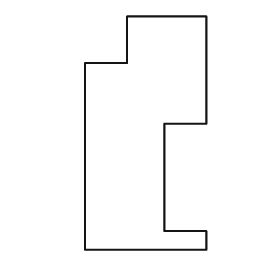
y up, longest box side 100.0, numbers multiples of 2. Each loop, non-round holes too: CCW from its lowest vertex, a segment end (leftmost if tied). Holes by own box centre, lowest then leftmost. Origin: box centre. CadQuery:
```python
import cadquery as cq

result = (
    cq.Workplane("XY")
    .moveTo(-26.0, -50.0)
    .lineTo(26.0, -50.0)
    .lineTo(26.0, -42.0)
    .lineTo(8.0, -42.0)
    .lineTo(8.0, 4.0)
    .lineTo(26.0, 4.0)
    .lineTo(26.0, 50.0)
    .lineTo(-8.0, 50.0)
    .lineTo(-8.0, 30.0)
    .lineTo(-26.0, 30.0)
    .close()
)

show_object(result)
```